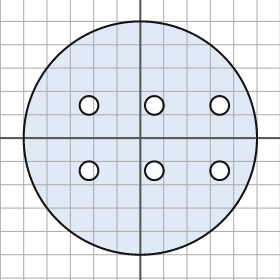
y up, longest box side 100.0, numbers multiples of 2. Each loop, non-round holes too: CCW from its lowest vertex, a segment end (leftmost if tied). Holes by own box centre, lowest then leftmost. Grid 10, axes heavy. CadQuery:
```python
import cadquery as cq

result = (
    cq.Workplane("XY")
    .moveTo(0.0, 0.0)
    .circle(50.0)
    .moveTo(-22.0, -14.0)
    .circle(4.0)
    .moveTo(6.0, -14.0)
    .circle(4.0)
    .moveTo(34.0, -14.0)
    .circle(4.0)
    .moveTo(-22.0, 14.0)
    .circle(4.0)
    .moveTo(6.0, 14.0)
    .circle(4.0)
    .moveTo(34.0, 14.0)
    .circle(4.0)
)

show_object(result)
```